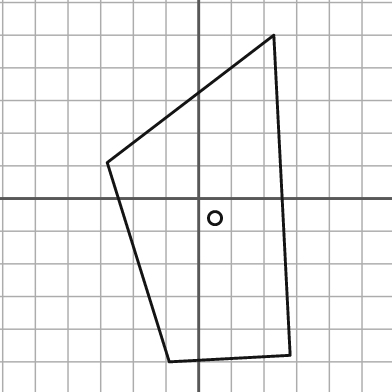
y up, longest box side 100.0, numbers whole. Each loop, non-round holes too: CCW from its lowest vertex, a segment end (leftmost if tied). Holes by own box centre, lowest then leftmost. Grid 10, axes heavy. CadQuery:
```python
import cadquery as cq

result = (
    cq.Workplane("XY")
    .moveTo(-9.0, -50.0)
    .lineTo(28.0, -48.0)
    .lineTo(23.0, 50.0)
    .lineTo(-28.0, 11.0)
    .close()
    .moveTo(5.0, -6.0)
    .circle(2.0)
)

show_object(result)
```